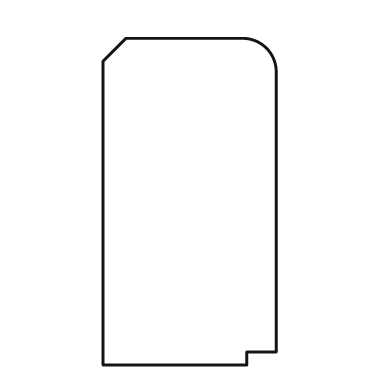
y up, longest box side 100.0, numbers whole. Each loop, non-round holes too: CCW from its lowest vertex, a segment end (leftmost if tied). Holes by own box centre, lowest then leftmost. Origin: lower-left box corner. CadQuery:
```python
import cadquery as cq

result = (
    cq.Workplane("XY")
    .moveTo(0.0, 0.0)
    .lineTo(44.0, 0.0)
    .lineTo(44.0, 4.0)
    .lineTo(53.0, 4.0)
    .lineTo(53.0, 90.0)
    .threePointArc((50.0, 97.0), (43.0, 100.0))
    .lineTo(7.0, 100.0)
    .lineTo(0.0, 93.0)
    .close()
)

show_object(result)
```